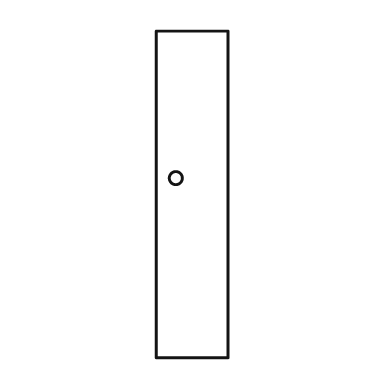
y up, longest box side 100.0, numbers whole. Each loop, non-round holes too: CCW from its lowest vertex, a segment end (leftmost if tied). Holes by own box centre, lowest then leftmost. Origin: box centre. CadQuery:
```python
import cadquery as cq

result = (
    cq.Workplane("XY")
    .moveTo(-11.0, -50.0)
    .lineTo(11.0, -50.0)
    .lineTo(11.0, 50.0)
    .lineTo(-11.0, 50.0)
    .close()
    .moveTo(-5.0, 5.0)
    .circle(2.0)
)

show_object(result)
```